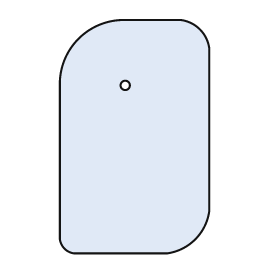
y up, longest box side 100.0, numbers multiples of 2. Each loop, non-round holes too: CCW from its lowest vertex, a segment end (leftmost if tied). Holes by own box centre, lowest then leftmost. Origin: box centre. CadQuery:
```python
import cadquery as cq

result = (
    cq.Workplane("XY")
    .moveTo(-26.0, -50.0)
    .lineTo(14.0, -50.0)
    .threePointArc((26.0, -44.0), (32.0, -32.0))
    .lineTo(32.0, 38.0)
    .threePointArc((28.0, 46.0), (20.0, 50.0))
    .lineTo(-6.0, 50.0)
    .threePointArc((-24.0, 42.0), (-32.0, 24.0))
    .lineTo(-32.0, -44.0)
    .threePointArc((-30.0, -48.0), (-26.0, -50.0))
    .close()
    .moveTo(-4.0, 22.0)
    .circle(2.0)
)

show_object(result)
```